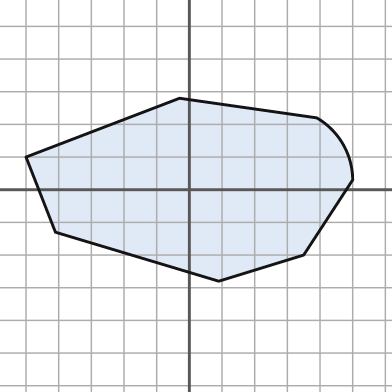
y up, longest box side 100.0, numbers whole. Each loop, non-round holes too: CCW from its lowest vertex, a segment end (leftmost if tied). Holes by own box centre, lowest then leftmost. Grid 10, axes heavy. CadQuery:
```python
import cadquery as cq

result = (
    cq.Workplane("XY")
    .moveTo(9.0, -28.0)
    .lineTo(35.0, -20.0)
    .lineTo(50.0, 3.0)
    .threePointArc((47.0, 14.0), (39.0, 22.0))
    .lineTo(-3.0, 28.0)
    .lineTo(-50.0, 10.0)
    .lineTo(-41.0, -13.0)
    .close()
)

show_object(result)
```